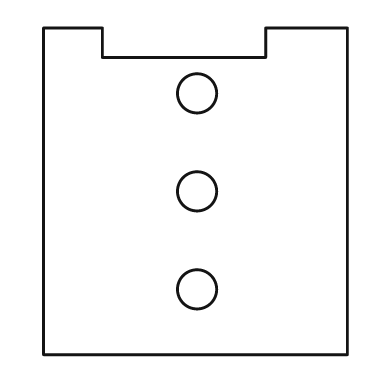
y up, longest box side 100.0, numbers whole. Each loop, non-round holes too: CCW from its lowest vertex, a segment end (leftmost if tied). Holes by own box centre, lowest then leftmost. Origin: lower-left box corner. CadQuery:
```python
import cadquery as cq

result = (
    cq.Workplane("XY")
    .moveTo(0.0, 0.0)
    .lineTo(93.0, 0.0)
    .lineTo(93.0, 100.0)
    .lineTo(68.0, 100.0)
    .lineTo(68.0, 91.0)
    .lineTo(18.0, 91.0)
    .lineTo(18.0, 100.0)
    .lineTo(0.0, 100.0)
    .close()
    .moveTo(47.0, 20.0)
    .circle(6.0)
    .moveTo(47.0, 50.0)
    .circle(6.0)
    .moveTo(47.0, 80.0)
    .circle(6.0)
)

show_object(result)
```